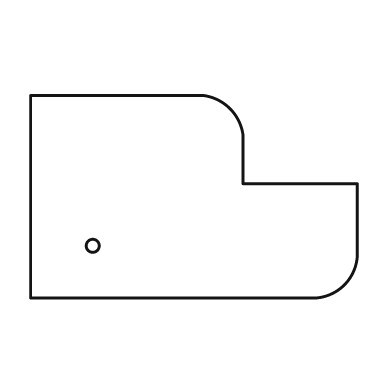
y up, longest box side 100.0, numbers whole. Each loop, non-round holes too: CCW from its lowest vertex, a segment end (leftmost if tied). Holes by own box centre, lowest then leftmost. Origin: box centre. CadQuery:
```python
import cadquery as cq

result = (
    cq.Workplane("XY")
    .moveTo(-50.0, -31.0)
    .lineTo(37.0, -31.0)
    .threePointArc((46.0, -27.0), (50.0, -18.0))
    .lineTo(50.0, 4.0)
    .lineTo(15.0, 4.0)
    .lineTo(15.0, 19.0)
    .threePointArc((11.0, 27.0), (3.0, 31.0))
    .lineTo(-50.0, 31.0)
    .close()
    .moveTo(-31.0, -15.0)
    .circle(2.0)
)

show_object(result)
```